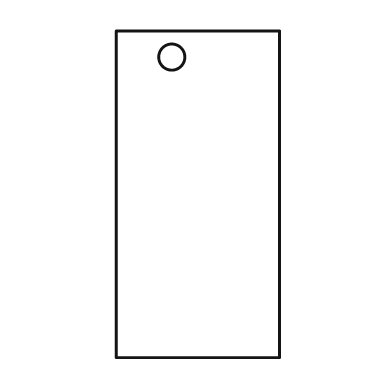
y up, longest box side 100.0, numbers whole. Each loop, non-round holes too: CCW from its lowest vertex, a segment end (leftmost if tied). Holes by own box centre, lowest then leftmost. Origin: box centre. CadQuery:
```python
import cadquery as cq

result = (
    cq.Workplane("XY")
    .moveTo(-25.0, -50.0)
    .lineTo(25.0, -50.0)
    .lineTo(25.0, 50.0)
    .lineTo(-25.0, 50.0)
    .close()
    .moveTo(-8.0, 42.0)
    .circle(4.0)
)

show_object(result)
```